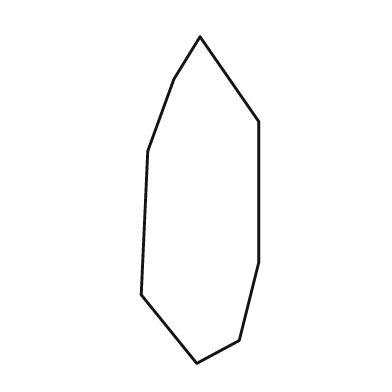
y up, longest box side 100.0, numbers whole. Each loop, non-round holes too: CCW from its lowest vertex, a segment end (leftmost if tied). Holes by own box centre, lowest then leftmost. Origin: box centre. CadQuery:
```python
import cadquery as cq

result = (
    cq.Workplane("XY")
    .moveTo(-1.0, -50.0)
    .lineTo(12.0, -43.0)
    .lineTo(18.0, -19.0)
    .lineTo(18.0, 24.0)
    .lineTo(0.0, 50.0)
    .lineTo(-8.0, 37.0)
    .lineTo(-16.0, 15.0)
    .lineTo(-18.0, -29.0)
    .close()
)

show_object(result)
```